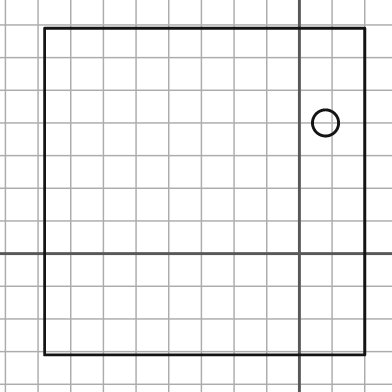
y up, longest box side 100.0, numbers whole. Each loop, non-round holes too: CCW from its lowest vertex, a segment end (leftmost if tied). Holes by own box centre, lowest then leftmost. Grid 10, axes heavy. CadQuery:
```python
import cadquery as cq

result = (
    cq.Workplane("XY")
    .moveTo(-78.0, -31.0)
    .lineTo(20.0, -31.0)
    .lineTo(20.0, 69.0)
    .lineTo(-78.0, 69.0)
    .close()
    .moveTo(8.0, 40.0)
    .circle(4.0)
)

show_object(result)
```